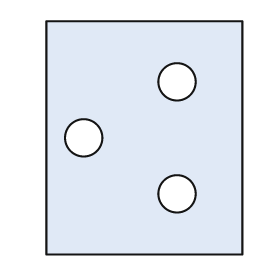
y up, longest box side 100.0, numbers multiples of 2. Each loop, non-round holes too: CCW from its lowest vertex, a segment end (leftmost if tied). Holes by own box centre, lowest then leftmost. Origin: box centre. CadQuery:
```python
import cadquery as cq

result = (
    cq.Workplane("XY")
    .moveTo(-42.0, -50.0)
    .lineTo(42.0, -50.0)
    .lineTo(42.0, 50.0)
    .lineTo(-42.0, 50.0)
    .close()
    .moveTo(14.0, -24.0)
    .circle(8.0)
    .moveTo(-26.0, 0.0)
    .circle(8.0)
    .moveTo(14.0, 24.0)
    .circle(8.0)
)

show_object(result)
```